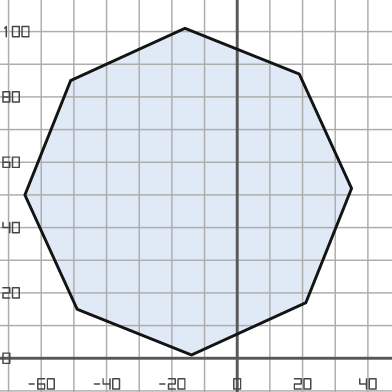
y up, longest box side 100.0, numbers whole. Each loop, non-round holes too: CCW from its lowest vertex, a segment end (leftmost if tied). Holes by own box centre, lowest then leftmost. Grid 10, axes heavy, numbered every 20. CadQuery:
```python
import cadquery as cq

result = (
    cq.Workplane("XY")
    .moveTo(-14.0, 1.0)
    .lineTo(21.0, 17.0)
    .lineTo(35.0, 52.0)
    .lineTo(19.0, 87.0)
    .lineTo(-16.0, 101.0)
    .lineTo(-51.0, 85.0)
    .lineTo(-65.0, 50.0)
    .lineTo(-49.0, 15.0)
    .close()
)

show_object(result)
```